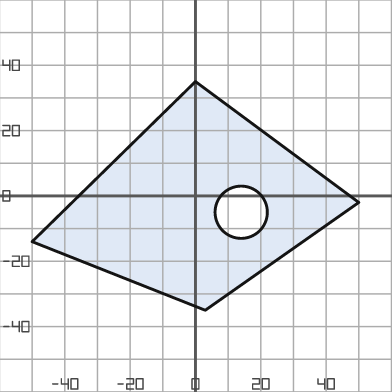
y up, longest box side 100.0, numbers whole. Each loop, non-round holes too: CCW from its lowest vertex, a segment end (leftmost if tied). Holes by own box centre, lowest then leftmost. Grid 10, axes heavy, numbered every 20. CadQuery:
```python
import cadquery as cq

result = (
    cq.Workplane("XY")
    .moveTo(3.0, -35.0)
    .lineTo(50.0, -2.0)
    .lineTo(0.0, 35.0)
    .lineTo(-50.0, -14.0)
    .close()
    .moveTo(14.0, -5.0)
    .circle(8.0)
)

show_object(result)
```